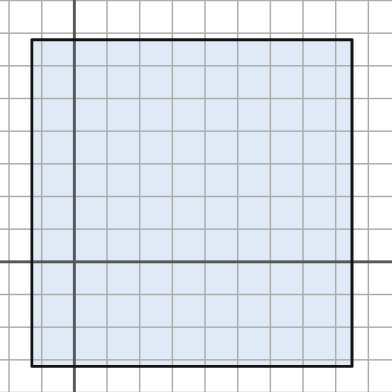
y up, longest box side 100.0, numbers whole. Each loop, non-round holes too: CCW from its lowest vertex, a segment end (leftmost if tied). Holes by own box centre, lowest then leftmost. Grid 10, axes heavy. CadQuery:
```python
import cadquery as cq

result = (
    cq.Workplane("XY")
    .moveTo(-13.0, -32.0)
    .lineTo(85.0, -32.0)
    .lineTo(85.0, 68.0)
    .lineTo(-13.0, 68.0)
    .close()
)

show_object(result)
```